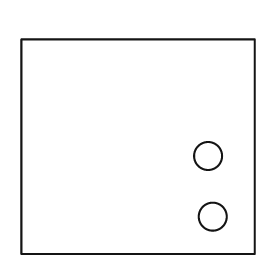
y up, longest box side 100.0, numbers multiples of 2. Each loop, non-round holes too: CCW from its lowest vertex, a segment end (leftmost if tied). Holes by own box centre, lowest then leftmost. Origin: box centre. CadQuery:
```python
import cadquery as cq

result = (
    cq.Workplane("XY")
    .moveTo(-50.0, -46.0)
    .lineTo(50.0, -46.0)
    .lineTo(50.0, 46.0)
    .lineTo(-50.0, 46.0)
    .close()
    .moveTo(32.0, -30.0)
    .circle(6.0)
    .moveTo(30.0, -4.0)
    .circle(6.0)
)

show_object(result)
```